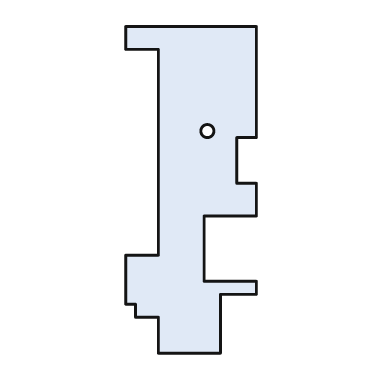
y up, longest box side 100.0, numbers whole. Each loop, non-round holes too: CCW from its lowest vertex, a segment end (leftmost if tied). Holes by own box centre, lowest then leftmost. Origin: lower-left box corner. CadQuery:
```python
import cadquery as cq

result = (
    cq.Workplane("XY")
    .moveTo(10.0, 0.0)
    .lineTo(29.0, 0.0)
    .lineTo(29.0, 18.0)
    .lineTo(40.0, 18.0)
    .lineTo(40.0, 22.0)
    .lineTo(24.0, 22.0)
    .lineTo(24.0, 42.0)
    .lineTo(40.0, 42.0)
    .lineTo(40.0, 52.0)
    .lineTo(34.0, 52.0)
    .lineTo(34.0, 66.0)
    .lineTo(40.0, 66.0)
    .lineTo(40.0, 100.0)
    .lineTo(0.0, 100.0)
    .lineTo(0.0, 93.0)
    .lineTo(10.0, 93.0)
    .lineTo(10.0, 30.0)
    .lineTo(0.0, 30.0)
    .lineTo(0.0, 15.0)
    .lineTo(3.0, 15.0)
    .lineTo(3.0, 11.0)
    .lineTo(10.0, 11.0)
    .close()
    .moveTo(25.0, 68.0)
    .circle(2.0)
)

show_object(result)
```